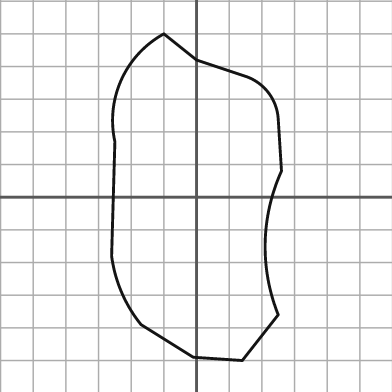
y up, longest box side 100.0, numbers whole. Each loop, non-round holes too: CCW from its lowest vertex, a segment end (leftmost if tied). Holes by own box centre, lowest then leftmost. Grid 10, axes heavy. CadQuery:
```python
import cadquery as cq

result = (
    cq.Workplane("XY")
    .moveTo(14.0, -50.0)
    .lineTo(25.0, -36.0)
    .threePointArc((21.0, -14.0), (26.0, 8.0))
    .lineTo(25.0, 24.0)
    .threePointArc((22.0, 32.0), (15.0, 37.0))
    .lineTo(0.0, 42.0)
    .lineTo(-10.0, 50.0)
    .threePointArc((-23.0, 36.0), (-25.0, 17.0))
    .lineTo(-26.0, -18.0)
    .threePointArc((-23.0, -29.0), (-17.0, -39.0))
    .lineTo(-1.0, -49.0)
    .close()
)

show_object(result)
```